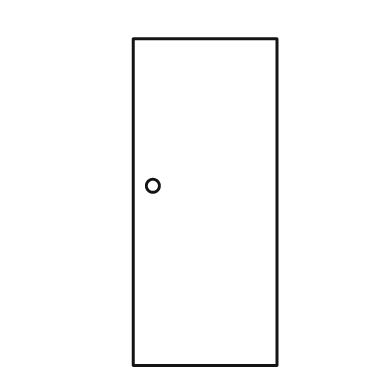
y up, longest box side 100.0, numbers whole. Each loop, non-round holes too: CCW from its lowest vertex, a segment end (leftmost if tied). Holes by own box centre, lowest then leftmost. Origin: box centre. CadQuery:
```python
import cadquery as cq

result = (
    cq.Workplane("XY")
    .moveTo(-22.0, -50.0)
    .lineTo(22.0, -50.0)
    .lineTo(22.0, 50.0)
    .lineTo(-22.0, 50.0)
    .close()
    .moveTo(-16.0, 5.0)
    .circle(2.0)
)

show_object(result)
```